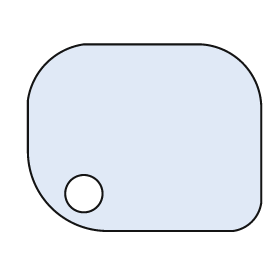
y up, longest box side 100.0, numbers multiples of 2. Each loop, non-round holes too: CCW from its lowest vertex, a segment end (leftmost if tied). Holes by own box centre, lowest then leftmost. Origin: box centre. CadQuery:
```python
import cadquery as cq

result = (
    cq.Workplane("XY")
    .moveTo(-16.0, -40.0)
    .lineTo(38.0, -40.0)
    .threePointArc((46.0, -36.0), (50.0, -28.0))
    .lineTo(50.0, 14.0)
    .threePointArc((42.0, 32.0), (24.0, 40.0))
    .lineTo(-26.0, 40.0)
    .threePointArc((-42.0, 32.0), (-50.0, 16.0))
    .lineTo(-50.0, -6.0)
    .threePointArc((-40.0, -30.0), (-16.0, -40.0))
    .close()
    .moveTo(-26.0, -24.0)
    .circle(8.0)
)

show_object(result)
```